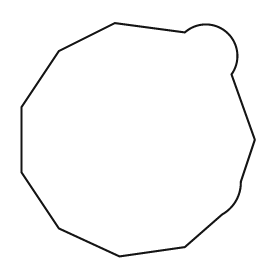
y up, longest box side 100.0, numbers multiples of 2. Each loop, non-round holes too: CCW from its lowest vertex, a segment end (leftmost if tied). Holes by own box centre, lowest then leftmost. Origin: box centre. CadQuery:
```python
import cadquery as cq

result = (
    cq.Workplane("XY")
    .moveTo(-8.0, -50.0)
    .lineTo(20.0, -46.0)
    .lineTo(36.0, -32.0)
    .threePointArc((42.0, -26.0), (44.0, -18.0))
    .lineTo(50.0, 0.0)
    .lineTo(40.0, 28.0)
    .threePointArc((38.0, 46.0), (20.0, 46.0))
    .lineTo(-10.0, 50.0)
    .lineTo(-34.0, 38.0)
    .lineTo(-50.0, 14.0)
    .lineTo(-50.0, -14.0)
    .lineTo(-34.0, -38.0)
    .close()
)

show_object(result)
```